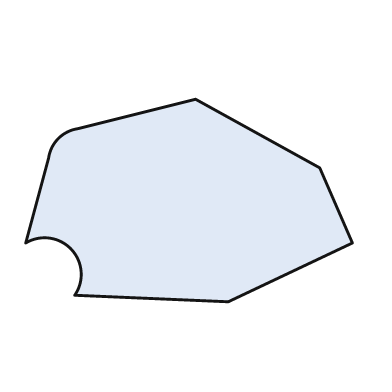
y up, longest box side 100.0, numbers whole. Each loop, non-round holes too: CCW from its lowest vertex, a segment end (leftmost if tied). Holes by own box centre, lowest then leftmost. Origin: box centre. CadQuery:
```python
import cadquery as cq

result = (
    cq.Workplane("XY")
    .moveTo(12.0, -31.0)
    .lineTo(50.0, -13.0)
    .lineTo(40.0, 10.0)
    .lineTo(2.0, 31.0)
    .lineTo(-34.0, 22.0)
    .threePointArc((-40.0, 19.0), (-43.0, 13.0))
    .lineTo(-50.0, -13.0)
    .threePointArc((-36.0, -15.0), (-35.0, -29.0))
    .close()
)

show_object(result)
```